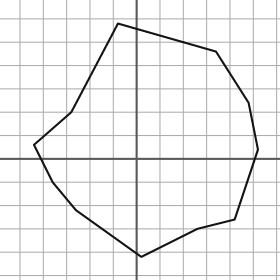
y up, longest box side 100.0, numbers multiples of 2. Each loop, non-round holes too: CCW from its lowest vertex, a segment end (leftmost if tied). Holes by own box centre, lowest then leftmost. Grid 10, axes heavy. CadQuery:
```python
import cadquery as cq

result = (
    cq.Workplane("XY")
    .moveTo(2.0, -42.0)
    .lineTo(26.0, -30.0)
    .lineTo(42.0, -26.0)
    .lineTo(52.0, 4.0)
    .lineTo(48.0, 24.0)
    .lineTo(34.0, 46.0)
    .lineTo(-8.0, 58.0)
    .lineTo(-28.0, 20.0)
    .lineTo(-44.0, 6.0)
    .lineTo(-36.0, -10.0)
    .lineTo(-26.0, -22.0)
    .close()
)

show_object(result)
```